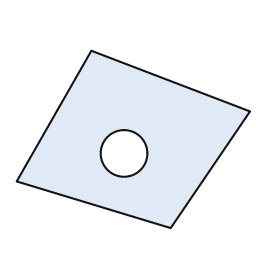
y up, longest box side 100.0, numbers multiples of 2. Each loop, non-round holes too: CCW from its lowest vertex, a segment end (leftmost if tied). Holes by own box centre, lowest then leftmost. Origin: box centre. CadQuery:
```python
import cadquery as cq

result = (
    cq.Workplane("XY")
    .moveTo(16.0, -38.0)
    .lineTo(50.0, 12.0)
    .lineTo(-18.0, 38.0)
    .lineTo(-50.0, -18.0)
    .close()
    .moveTo(-4.0, -6.0)
    .circle(10.0)
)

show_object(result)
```